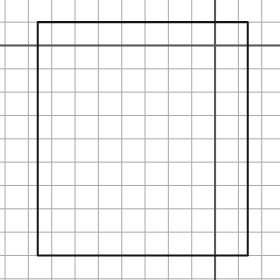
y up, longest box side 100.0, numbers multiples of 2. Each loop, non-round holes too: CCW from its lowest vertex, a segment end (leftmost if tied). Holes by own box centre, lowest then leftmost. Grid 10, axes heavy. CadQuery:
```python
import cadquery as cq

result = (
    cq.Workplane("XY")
    .moveTo(-76.0, -90.0)
    .lineTo(14.0, -90.0)
    .lineTo(14.0, 10.0)
    .lineTo(-76.0, 10.0)
    .close()
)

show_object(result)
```